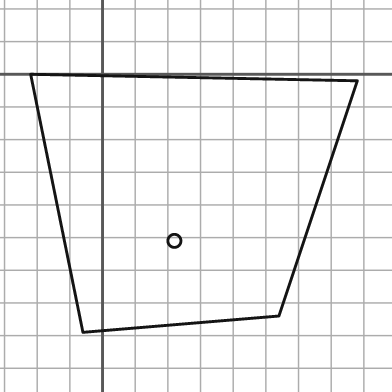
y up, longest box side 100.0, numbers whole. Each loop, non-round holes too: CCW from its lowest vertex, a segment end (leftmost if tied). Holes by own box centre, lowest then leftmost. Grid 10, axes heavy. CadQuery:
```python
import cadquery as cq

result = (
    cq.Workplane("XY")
    .moveTo(-6.0, -79.0)
    .lineTo(54.0, -74.0)
    .lineTo(78.0, -2.0)
    .lineTo(-22.0, 0.0)
    .close()
    .moveTo(22.0, -51.0)
    .circle(2.0)
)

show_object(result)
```